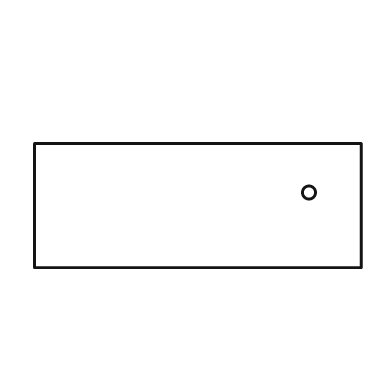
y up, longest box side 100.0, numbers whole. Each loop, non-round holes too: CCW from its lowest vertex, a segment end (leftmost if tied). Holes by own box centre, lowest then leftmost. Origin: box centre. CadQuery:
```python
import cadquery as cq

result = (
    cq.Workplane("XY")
    .moveTo(-50.0, -19.0)
    .lineTo(50.0, -19.0)
    .lineTo(50.0, 19.0)
    .lineTo(-50.0, 19.0)
    .close()
    .moveTo(34.0, 4.0)
    .circle(2.0)
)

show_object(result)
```